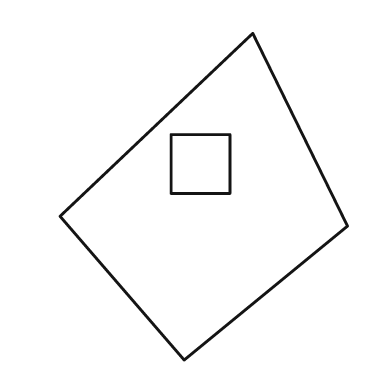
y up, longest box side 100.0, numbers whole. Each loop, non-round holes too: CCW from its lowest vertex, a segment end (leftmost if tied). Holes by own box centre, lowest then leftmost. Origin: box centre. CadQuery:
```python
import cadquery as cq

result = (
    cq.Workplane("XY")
    .moveTo(-6.0, -50.0)
    .lineTo(44.0, -9.0)
    .lineTo(15.0, 50.0)
    .lineTo(-44.0, -6.0)
    .close()
    .moveTo(-10.0, 1.0)
    .lineTo(8.0, 1.0)
    .lineTo(8.0, 19.0)
    .lineTo(-10.0, 19.0)
    .close()
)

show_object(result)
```